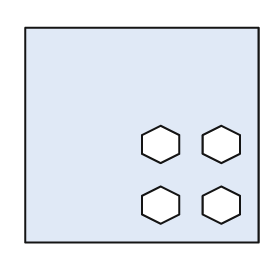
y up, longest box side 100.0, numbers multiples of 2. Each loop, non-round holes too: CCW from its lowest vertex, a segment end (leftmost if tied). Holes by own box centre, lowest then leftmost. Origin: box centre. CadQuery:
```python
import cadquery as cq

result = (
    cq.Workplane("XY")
    .moveTo(-50.0, -46.0)
    .lineTo(50.0, -46.0)
    .lineTo(50.0, 46.0)
    .lineTo(-50.0, 46.0)
    .close()
    .moveTo(8.0, -38.0)
    .lineTo(16.0, -34.0)
    .lineTo(16.0, -26.0)
    .lineTo(8.0, -22.0)
    .lineTo(0.0, -26.0)
    .lineTo(0.0, -34.0)
    .close()
    .moveTo(34.0, -38.0)
    .lineTo(42.0, -34.0)
    .lineTo(42.0, -26.0)
    .lineTo(34.0, -22.0)
    .lineTo(26.0, -26.0)
    .lineTo(26.0, -34.0)
    .close()
    .moveTo(8.0, -12.0)
    .lineTo(16.0, -8.0)
    .lineTo(16.0, 0.0)
    .lineTo(8.0, 4.0)
    .lineTo(0.0, 0.0)
    .lineTo(0.0, -8.0)
    .close()
    .moveTo(34.0, -12.0)
    .lineTo(42.0, -8.0)
    .lineTo(42.0, 0.0)
    .lineTo(34.0, 4.0)
    .lineTo(26.0, 0.0)
    .lineTo(26.0, -8.0)
    .close()
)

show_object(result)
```